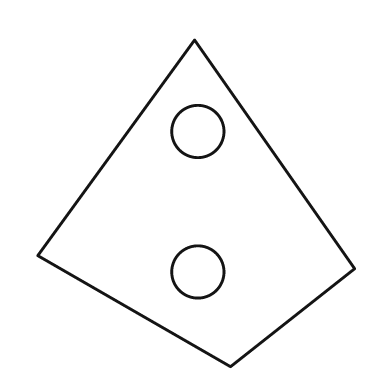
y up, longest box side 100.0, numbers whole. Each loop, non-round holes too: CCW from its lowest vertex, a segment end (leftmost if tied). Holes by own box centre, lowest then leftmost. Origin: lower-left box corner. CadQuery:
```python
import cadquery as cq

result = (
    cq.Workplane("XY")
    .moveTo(59.0, 0.0)
    .lineTo(97.0, 30.0)
    .lineTo(48.0, 100.0)
    .lineTo(0.0, 34.0)
    .close()
    .moveTo(49.0, 29.0)
    .circle(8.0)
    .moveTo(49.0, 72.0)
    .circle(8.0)
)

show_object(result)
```